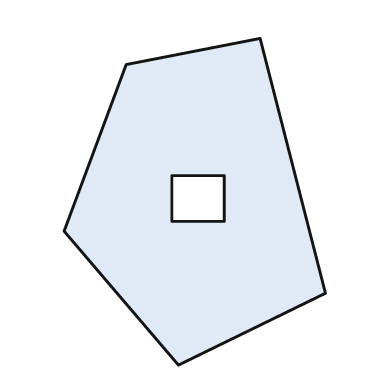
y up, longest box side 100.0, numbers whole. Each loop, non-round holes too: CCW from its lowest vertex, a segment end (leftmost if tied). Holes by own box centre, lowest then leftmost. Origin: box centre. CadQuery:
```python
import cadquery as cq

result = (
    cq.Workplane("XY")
    .moveTo(-5.0, -50.0)
    .lineTo(40.0, -28.0)
    .lineTo(20.0, 50.0)
    .lineTo(-21.0, 42.0)
    .lineTo(-40.0, -9.0)
    .close()
    .moveTo(-7.0, -6.0)
    .lineTo(9.0, -6.0)
    .lineTo(9.0, 8.0)
    .lineTo(-7.0, 8.0)
    .close()
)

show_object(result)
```